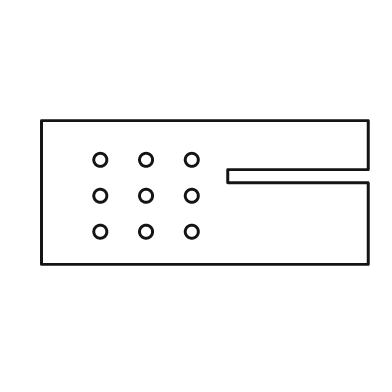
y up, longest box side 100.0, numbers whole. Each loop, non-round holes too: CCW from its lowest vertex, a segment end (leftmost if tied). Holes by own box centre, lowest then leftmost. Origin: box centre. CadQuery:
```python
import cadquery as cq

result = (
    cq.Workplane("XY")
    .moveTo(-50.0, -22.0)
    .lineTo(50.0, -22.0)
    .lineTo(50.0, 3.0)
    .lineTo(7.0, 3.0)
    .lineTo(7.0, 7.0)
    .lineTo(50.0, 7.0)
    .lineTo(50.0, 22.0)
    .lineTo(-50.0, 22.0)
    .close()
    .moveTo(-32.0, -12.0)
    .circle(2.0)
    .moveTo(-18.0, -12.0)
    .circle(2.0)
    .moveTo(-4.0, -12.0)
    .circle(2.0)
    .moveTo(-32.0, -1.0)
    .circle(2.0)
    .moveTo(-18.0, -1.0)
    .circle(2.0)
    .moveTo(-4.0, -1.0)
    .circle(2.0)
    .moveTo(-32.0, 10.0)
    .circle(2.0)
    .moveTo(-18.0, 10.0)
    .circle(2.0)
    .moveTo(-4.0, 10.0)
    .circle(2.0)
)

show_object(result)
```